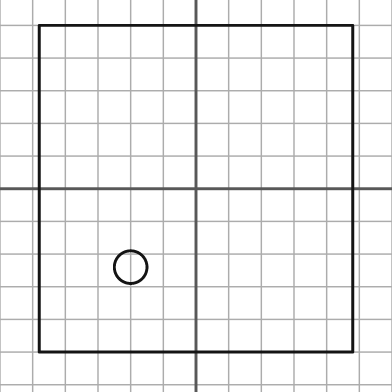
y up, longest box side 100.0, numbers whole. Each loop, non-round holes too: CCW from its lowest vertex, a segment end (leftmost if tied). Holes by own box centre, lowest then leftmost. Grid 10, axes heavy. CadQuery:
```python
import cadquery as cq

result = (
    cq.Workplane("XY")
    .moveTo(-48.0, -50.0)
    .lineTo(48.0, -50.0)
    .lineTo(48.0, 50.0)
    .lineTo(-48.0, 50.0)
    .close()
    .moveTo(-20.0, -24.0)
    .circle(5.0)
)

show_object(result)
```